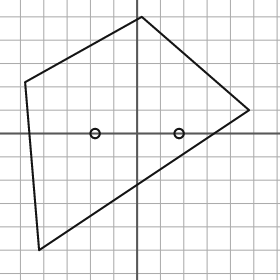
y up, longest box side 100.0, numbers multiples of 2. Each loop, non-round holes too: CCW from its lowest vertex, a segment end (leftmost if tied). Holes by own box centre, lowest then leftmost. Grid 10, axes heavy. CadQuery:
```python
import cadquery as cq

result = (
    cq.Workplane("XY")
    .moveTo(-42.0, -50.0)
    .lineTo(48.0, 10.0)
    .lineTo(2.0, 50.0)
    .lineTo(-48.0, 22.0)
    .close()
    .moveTo(-18.0, 0.0)
    .circle(2.0)
    .moveTo(18.0, 0.0)
    .circle(2.0)
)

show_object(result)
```